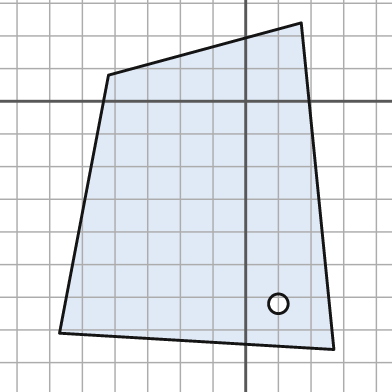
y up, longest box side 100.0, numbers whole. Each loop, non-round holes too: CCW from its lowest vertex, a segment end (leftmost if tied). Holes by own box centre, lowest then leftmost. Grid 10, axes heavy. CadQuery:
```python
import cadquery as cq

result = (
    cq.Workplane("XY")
    .moveTo(27.0, -76.0)
    .lineTo(17.0, 24.0)
    .lineTo(-42.0, 8.0)
    .lineTo(-57.0, -71.0)
    .close()
    .moveTo(10.0, -62.0)
    .circle(3.0)
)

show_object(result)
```